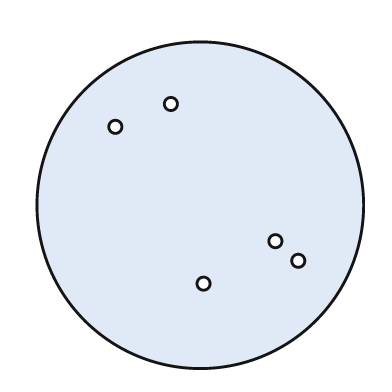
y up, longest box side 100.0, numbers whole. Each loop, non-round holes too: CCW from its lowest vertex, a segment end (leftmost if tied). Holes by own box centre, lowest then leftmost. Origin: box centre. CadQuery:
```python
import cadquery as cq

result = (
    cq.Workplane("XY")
    .moveTo(0.0, 0.0)
    .circle(50.0)
    .moveTo(1.0, -24.0)
    .circle(2.0)
    .moveTo(30.0, -17.0)
    .circle(2.0)
    .moveTo(23.0, -11.0)
    .circle(2.0)
    .moveTo(-26.0, 24.0)
    .circle(2.0)
    .moveTo(-9.0, 31.0)
    .circle(2.0)
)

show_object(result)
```